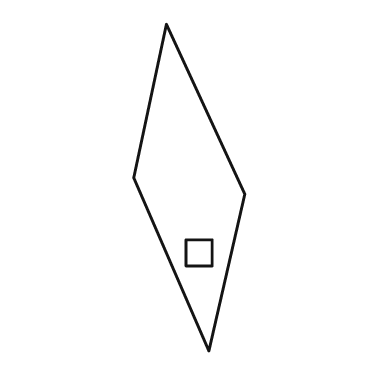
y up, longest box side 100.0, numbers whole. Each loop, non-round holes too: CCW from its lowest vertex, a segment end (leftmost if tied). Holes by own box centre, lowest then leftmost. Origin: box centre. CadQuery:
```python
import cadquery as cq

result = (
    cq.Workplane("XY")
    .moveTo(6.0, -50.0)
    .lineTo(17.0, -2.0)
    .lineTo(-7.0, 50.0)
    .lineTo(-17.0, 3.0)
    .close()
    .moveTo(-1.0, -24.0)
    .lineTo(7.0, -24.0)
    .lineTo(7.0, -16.0)
    .lineTo(-1.0, -16.0)
    .close()
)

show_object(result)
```